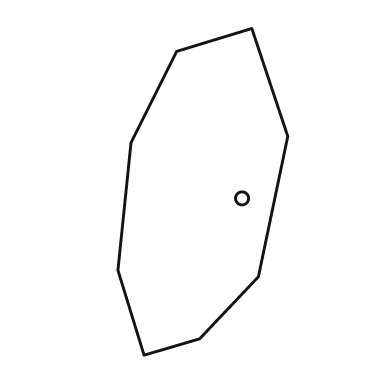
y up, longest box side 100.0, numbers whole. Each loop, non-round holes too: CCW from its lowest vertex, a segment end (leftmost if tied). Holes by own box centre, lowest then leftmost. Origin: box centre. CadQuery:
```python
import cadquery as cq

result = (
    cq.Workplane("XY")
    .moveTo(-18.0, -50.0)
    .lineTo(-1.0, -45.0)
    .lineTo(17.0, -26.0)
    .lineTo(26.0, 17.0)
    .lineTo(15.0, 50.0)
    .lineTo(-8.0, 43.0)
    .lineTo(-22.0, 15.0)
    .lineTo(-26.0, -24.0)
    .close()
    .moveTo(12.0, -2.0)
    .circle(2.0)
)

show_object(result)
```